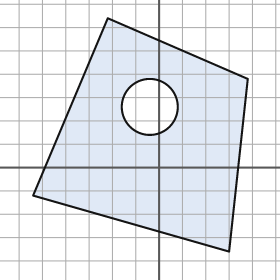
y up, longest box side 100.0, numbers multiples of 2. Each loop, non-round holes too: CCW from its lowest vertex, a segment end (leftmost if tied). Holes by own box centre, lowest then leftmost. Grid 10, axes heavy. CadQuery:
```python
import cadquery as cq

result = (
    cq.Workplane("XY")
    .moveTo(30.0, -36.0)
    .lineTo(38.0, 38.0)
    .lineTo(-22.0, 64.0)
    .lineTo(-54.0, -12.0)
    .close()
    .moveTo(-4.0, 26.0)
    .circle(12.0)
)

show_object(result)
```